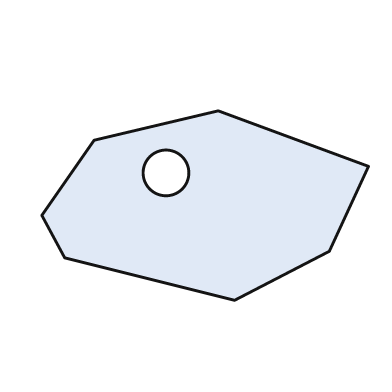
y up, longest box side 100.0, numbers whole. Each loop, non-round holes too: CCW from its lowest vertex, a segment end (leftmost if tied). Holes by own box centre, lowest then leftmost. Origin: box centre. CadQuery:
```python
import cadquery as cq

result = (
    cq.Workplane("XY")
    .moveTo(9.0, -29.0)
    .lineTo(38.0, -14.0)
    .lineTo(50.0, 12.0)
    .lineTo(4.0, 29.0)
    .lineTo(-34.0, 20.0)
    .lineTo(-50.0, -3.0)
    .lineTo(-43.0, -16.0)
    .close()
    .moveTo(-12.0, 10.0)
    .circle(7.0)
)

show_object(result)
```